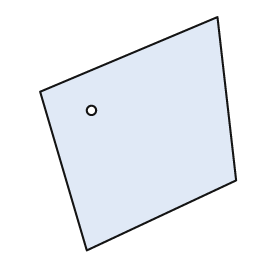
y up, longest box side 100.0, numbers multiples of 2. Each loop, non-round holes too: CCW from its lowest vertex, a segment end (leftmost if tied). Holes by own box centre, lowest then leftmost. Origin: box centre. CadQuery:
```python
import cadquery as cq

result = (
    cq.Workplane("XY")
    .moveTo(-22.0, -50.0)
    .lineTo(42.0, -20.0)
    .lineTo(34.0, 50.0)
    .lineTo(-42.0, 18.0)
    .close()
    .moveTo(-20.0, 10.0)
    .circle(2.0)
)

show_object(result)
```